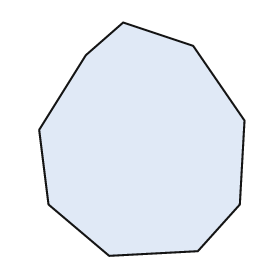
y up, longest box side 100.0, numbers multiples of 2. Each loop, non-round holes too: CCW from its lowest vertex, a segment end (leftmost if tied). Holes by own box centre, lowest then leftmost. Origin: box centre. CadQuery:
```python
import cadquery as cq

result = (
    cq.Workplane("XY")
    .moveTo(-14.0, -50.0)
    .lineTo(24.0, -48.0)
    .lineTo(42.0, -28.0)
    .lineTo(44.0, 8.0)
    .lineTo(22.0, 40.0)
    .lineTo(-8.0, 50.0)
    .lineTo(-24.0, 36.0)
    .lineTo(-44.0, 4.0)
    .lineTo(-40.0, -28.0)
    .close()
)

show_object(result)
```